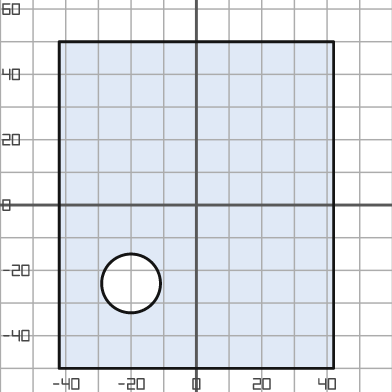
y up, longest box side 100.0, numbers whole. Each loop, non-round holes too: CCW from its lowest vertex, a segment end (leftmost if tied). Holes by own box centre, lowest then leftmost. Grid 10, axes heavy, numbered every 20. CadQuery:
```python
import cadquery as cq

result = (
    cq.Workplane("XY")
    .moveTo(-42.0, -50.0)
    .lineTo(42.0, -50.0)
    .lineTo(42.0, 50.0)
    .lineTo(-42.0, 50.0)
    .close()
    .moveTo(-20.0, -24.0)
    .circle(9.0)
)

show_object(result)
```